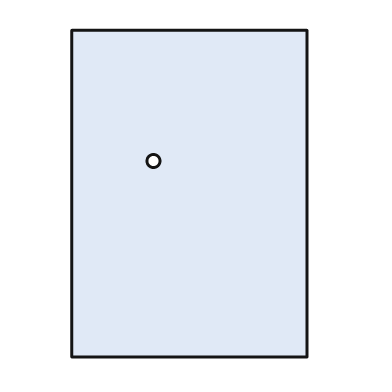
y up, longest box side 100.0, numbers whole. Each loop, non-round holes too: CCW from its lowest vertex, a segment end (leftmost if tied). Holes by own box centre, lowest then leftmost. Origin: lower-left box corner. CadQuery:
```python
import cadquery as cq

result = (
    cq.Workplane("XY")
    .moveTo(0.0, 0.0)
    .lineTo(72.0, 0.0)
    .lineTo(72.0, 100.0)
    .lineTo(0.0, 100.0)
    .close()
    .moveTo(25.0, 60.0)
    .circle(2.0)
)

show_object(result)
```